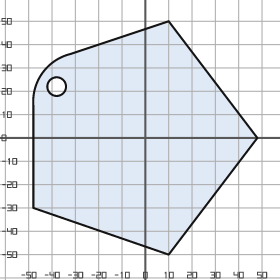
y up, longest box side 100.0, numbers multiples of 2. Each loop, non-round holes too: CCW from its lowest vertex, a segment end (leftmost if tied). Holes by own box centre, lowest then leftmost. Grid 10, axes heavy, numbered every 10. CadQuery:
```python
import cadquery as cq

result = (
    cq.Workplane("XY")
    .moveTo(10.0, -50.0)
    .lineTo(48.0, 0.0)
    .lineTo(10.0, 50.0)
    .lineTo(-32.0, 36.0)
    .threePointArc((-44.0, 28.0), (-48.0, 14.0))
    .lineTo(-48.0, -30.0)
    .close()
    .moveTo(-38.0, 22.0)
    .circle(4.0)
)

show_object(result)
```